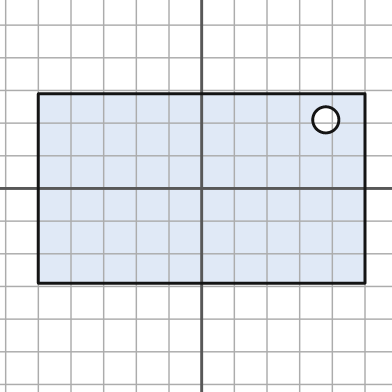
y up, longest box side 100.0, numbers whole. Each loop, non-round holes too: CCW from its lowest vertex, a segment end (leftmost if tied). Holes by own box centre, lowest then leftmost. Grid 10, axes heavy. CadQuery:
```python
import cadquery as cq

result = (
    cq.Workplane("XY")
    .moveTo(-50.0, -29.0)
    .lineTo(50.0, -29.0)
    .lineTo(50.0, 29.0)
    .lineTo(-50.0, 29.0)
    .close()
    .moveTo(38.0, 21.0)
    .circle(4.0)
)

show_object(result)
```